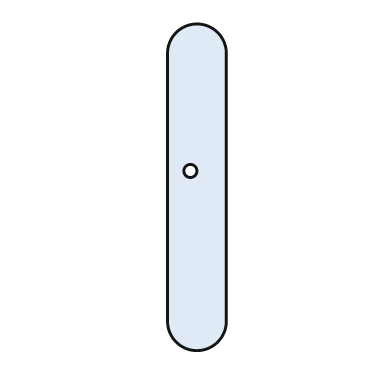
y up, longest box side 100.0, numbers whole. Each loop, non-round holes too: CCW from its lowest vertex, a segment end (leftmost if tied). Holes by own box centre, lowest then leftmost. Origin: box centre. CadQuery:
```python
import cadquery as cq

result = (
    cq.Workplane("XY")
    .moveTo(-9.0, -41.0)
    .threePointArc((0.0, -50.0), (9.0, -41.0))
    .lineTo(9.0, 41.0)
    .threePointArc((0.0, 50.0), (-9.0, 41.0))
    .close()
    .moveTo(-2.0, 5.0)
    .circle(2.0)
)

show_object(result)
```